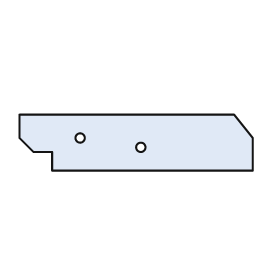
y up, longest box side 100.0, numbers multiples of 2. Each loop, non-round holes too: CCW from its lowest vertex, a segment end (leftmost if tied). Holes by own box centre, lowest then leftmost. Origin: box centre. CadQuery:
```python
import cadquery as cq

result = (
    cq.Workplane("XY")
    .moveTo(-36.0, -12.0)
    .lineTo(50.0, -12.0)
    .lineTo(50.0, 2.0)
    .lineTo(42.0, 12.0)
    .lineTo(-50.0, 12.0)
    .lineTo(-50.0, 2.0)
    .lineTo(-44.0, -4.0)
    .lineTo(-36.0, -4.0)
    .close()
    .moveTo(2.0, -2.0)
    .circle(2.0)
    .moveTo(-24.0, 2.0)
    .circle(2.0)
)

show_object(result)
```